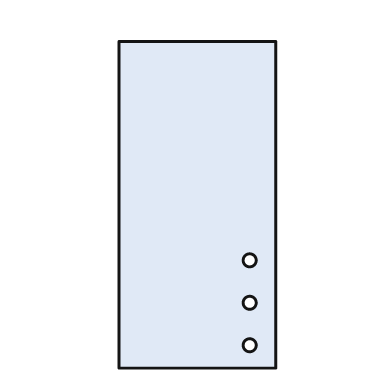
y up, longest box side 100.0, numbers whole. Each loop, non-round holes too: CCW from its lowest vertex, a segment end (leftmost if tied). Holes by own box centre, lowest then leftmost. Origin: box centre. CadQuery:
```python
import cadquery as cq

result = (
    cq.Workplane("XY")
    .moveTo(-24.0, -50.0)
    .lineTo(24.0, -50.0)
    .lineTo(24.0, 50.0)
    .lineTo(-24.0, 50.0)
    .close()
    .moveTo(16.0, -43.0)
    .circle(2.0)
    .moveTo(16.0, -30.0)
    .circle(2.0)
    .moveTo(16.0, -17.0)
    .circle(2.0)
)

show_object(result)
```